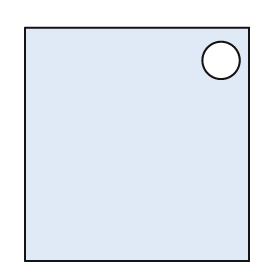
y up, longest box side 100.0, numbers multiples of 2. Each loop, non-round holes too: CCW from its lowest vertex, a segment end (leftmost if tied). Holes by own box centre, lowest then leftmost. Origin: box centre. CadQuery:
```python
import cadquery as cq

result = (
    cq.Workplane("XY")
    .moveTo(-48.0, -50.0)
    .lineTo(48.0, -50.0)
    .lineTo(48.0, 50.0)
    .lineTo(-48.0, 50.0)
    .close()
    .moveTo(36.0, 36.0)
    .circle(8.0)
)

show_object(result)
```